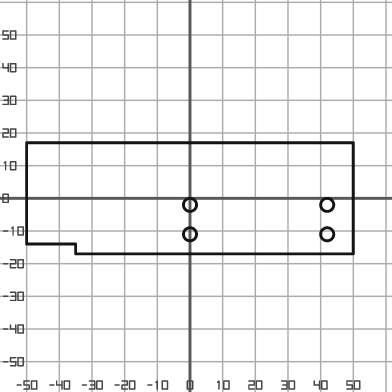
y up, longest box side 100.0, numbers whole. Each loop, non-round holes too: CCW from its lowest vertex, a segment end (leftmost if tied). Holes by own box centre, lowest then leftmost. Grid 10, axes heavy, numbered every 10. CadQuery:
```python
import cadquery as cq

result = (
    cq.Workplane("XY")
    .moveTo(-35.0, -17.0)
    .lineTo(50.0, -17.0)
    .lineTo(50.0, 17.0)
    .lineTo(-50.0, 17.0)
    .lineTo(-50.0, -14.0)
    .lineTo(-35.0, -14.0)
    .close()
    .moveTo(0.0, -11.0)
    .circle(2.0)
    .moveTo(42.0, -11.0)
    .circle(2.0)
    .moveTo(0.0, -2.0)
    .circle(2.0)
    .moveTo(42.0, -2.0)
    .circle(2.0)
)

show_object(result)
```